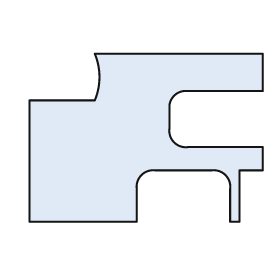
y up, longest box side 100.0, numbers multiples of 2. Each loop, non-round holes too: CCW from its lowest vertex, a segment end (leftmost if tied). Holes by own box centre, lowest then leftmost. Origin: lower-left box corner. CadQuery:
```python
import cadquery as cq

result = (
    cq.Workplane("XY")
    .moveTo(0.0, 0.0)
    .lineTo(46.0, 0.0)
    .lineTo(46.0, 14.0)
    .threePointArc((48.0, 20.0), (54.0, 22.0))
    .lineTo(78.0, 22.0)
    .threePointArc((84.0, 20.0), (86.0, 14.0))
    .lineTo(86.0, 0.0)
    .lineTo(90.0, 0.0)
    .lineTo(90.0, 22.0)
    .lineTo(100.0, 22.0)
    .lineTo(100.0, 32.0)
    .lineTo(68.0, 32.0)
    .threePointArc((62.0, 34.0), (60.0, 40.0))
    .lineTo(60.0, 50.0)
    .threePointArc((62.0, 54.0), (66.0, 56.0))
    .lineTo(100.0, 56.0)
    .lineTo(100.0, 72.0)
    .lineTo(28.0, 72.0)
    .threePointArc((30.0, 62.0), (28.0, 52.0))
    .lineTo(0.0, 52.0)
    .close()
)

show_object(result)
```